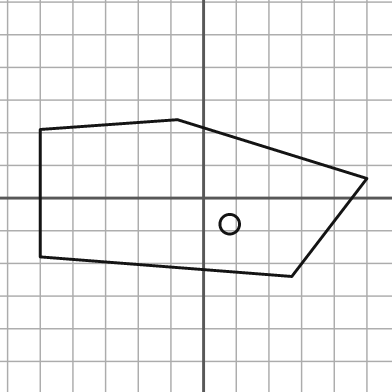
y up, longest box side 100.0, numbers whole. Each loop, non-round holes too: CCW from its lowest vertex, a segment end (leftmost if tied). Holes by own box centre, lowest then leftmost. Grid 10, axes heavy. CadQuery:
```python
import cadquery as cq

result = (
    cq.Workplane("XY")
    .moveTo(27.0, -24.0)
    .lineTo(50.0, 6.0)
    .lineTo(-8.0, 24.0)
    .lineTo(-50.0, 21.0)
    .lineTo(-50.0, -18.0)
    .close()
    .moveTo(8.0, -8.0)
    .circle(3.0)
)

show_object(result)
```